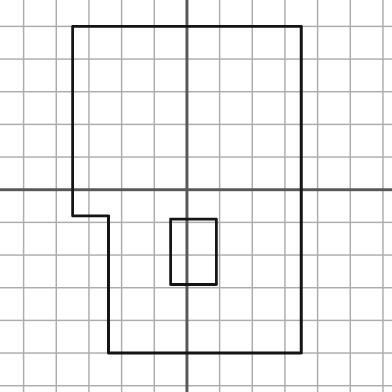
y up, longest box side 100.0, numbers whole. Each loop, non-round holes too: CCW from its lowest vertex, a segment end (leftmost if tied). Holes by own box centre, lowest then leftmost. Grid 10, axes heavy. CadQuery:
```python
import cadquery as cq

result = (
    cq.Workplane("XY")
    .moveTo(-24.0, -50.0)
    .lineTo(35.0, -50.0)
    .lineTo(35.0, 50.0)
    .lineTo(-35.0, 50.0)
    .lineTo(-35.0, -8.0)
    .lineTo(-24.0, -8.0)
    .close()
    .moveTo(-5.0, -29.0)
    .lineTo(9.0, -29.0)
    .lineTo(9.0, -9.0)
    .lineTo(-5.0, -9.0)
    .close()
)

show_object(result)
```